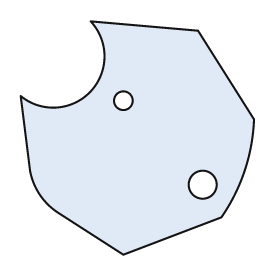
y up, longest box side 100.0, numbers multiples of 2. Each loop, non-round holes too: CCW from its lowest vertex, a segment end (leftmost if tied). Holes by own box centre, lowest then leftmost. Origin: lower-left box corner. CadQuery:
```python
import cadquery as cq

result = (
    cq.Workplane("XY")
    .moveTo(44.0, 0.0)
    .lineTo(86.0, 16.0)
    .threePointArc((96.0, 36.0), (100.0, 58.0))
    .lineTo(76.0, 96.0)
    .lineTo(30.0, 100.0)
    .threePointArc((30.0, 70.0), (0.0, 68.0))
    .lineTo(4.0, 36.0)
    .threePointArc((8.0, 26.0), (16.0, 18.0))
    .close()
    .moveTo(78.0, 30.0)
    .circle(6.0)
    .moveTo(44.0, 66.0)
    .circle(4.0)
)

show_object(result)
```